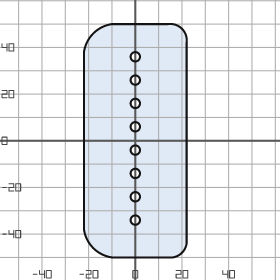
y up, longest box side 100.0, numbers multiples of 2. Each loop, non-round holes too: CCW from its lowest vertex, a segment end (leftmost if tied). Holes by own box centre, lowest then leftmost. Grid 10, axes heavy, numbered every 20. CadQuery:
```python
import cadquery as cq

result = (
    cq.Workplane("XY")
    .moveTo(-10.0, -50.0)
    .lineTo(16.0, -50.0)
    .threePointArc((20.0, -48.0), (22.0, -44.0))
    .lineTo(22.0, 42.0)
    .threePointArc((20.0, 48.0), (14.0, 50.0))
    .lineTo(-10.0, 50.0)
    .threePointArc((-18.0, 46.0), (-22.0, 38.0))
    .lineTo(-22.0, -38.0)
    .threePointArc((-18.0, -46.0), (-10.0, -50.0))
    .close()
    .moveTo(0.0, -34.0)
    .circle(2.0)
    .moveTo(0.0, -24.0)
    .circle(2.0)
    .moveTo(0.0, -14.0)
    .circle(2.0)
    .moveTo(0.0, -4.0)
    .circle(2.0)
    .moveTo(0.0, 6.0)
    .circle(2.0)
    .moveTo(0.0, 16.0)
    .circle(2.0)
    .moveTo(0.0, 26.0)
    .circle(2.0)
    .moveTo(0.0, 36.0)
    .circle(2.0)
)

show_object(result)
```